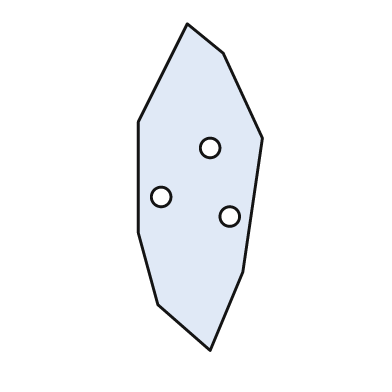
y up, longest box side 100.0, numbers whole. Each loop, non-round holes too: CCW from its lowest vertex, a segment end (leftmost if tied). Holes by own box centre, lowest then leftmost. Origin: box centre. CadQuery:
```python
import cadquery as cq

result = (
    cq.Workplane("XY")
    .moveTo(3.0, -50.0)
    .lineTo(13.0, -26.0)
    .lineTo(19.0, 15.0)
    .lineTo(7.0, 41.0)
    .lineTo(-4.0, 50.0)
    .lineTo(-19.0, 20.0)
    .lineTo(-19.0, -14.0)
    .lineTo(-13.0, -36.0)
    .close()
    .moveTo(9.0, -9.0)
    .circle(3.0)
    .moveTo(-12.0, -3.0)
    .circle(3.0)
    .moveTo(3.0, 12.0)
    .circle(3.0)
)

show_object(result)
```